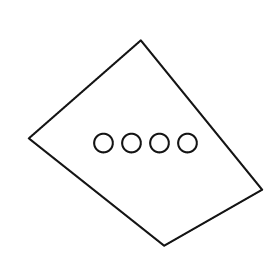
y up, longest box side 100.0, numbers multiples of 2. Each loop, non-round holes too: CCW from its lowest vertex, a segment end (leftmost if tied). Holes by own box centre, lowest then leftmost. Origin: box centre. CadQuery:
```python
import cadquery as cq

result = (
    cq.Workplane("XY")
    .moveTo(8.0, -44.0)
    .lineTo(50.0, -20.0)
    .lineTo(-2.0, 44.0)
    .lineTo(-50.0, 2.0)
    .close()
    .moveTo(-18.0, 0.0)
    .circle(4.0)
    .moveTo(-6.0, 0.0)
    .circle(4.0)
    .moveTo(6.0, 0.0)
    .circle(4.0)
    .moveTo(18.0, 0.0)
    .circle(4.0)
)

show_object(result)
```